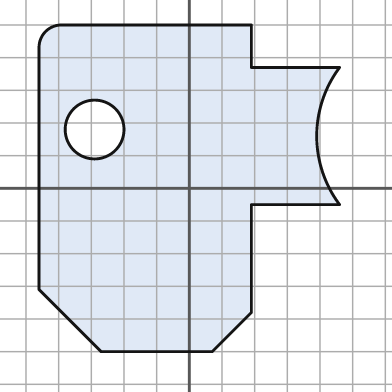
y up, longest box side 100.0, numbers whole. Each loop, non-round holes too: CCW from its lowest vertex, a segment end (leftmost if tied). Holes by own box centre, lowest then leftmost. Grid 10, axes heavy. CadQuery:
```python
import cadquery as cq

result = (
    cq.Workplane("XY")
    .moveTo(-27.0, -50.0)
    .lineTo(7.0, -50.0)
    .lineTo(19.0, -38.0)
    .lineTo(19.0, -5.0)
    .lineTo(46.0, -5.0)
    .threePointArc((39.0, 16.0), (46.0, 37.0))
    .lineTo(19.0, 37.0)
    .lineTo(19.0, 50.0)
    .lineTo(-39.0, 50.0)
    .threePointArc((-44.0, 48.0), (-46.0, 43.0))
    .lineTo(-46.0, -31.0)
    .close()
    .moveTo(-29.0, 18.0)
    .circle(9.0)
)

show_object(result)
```